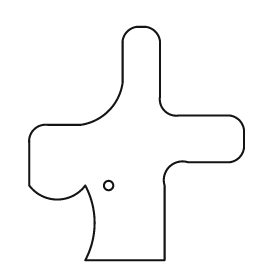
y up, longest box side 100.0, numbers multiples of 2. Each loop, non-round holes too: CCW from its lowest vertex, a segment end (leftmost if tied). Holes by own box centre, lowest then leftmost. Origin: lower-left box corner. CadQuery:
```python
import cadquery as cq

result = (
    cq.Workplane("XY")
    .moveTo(24.0, 0.0)
    .lineTo(58.0, 0.0)
    .lineTo(58.0, 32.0)
    .threePointArc((60.0, 40.0), (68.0, 42.0))
    .lineTo(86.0, 42.0)
    .threePointArc((90.0, 44.0), (92.0, 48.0))
    .lineTo(92.0, 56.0)
    .threePointArc((90.0, 60.0), (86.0, 62.0))
    .lineTo(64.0, 62.0)
    .threePointArc((58.0, 64.0), (56.0, 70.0))
    .lineTo(56.0, 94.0)
    .threePointArc((54.0, 98.0), (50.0, 100.0))
    .lineTo(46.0, 100.0)
    .threePointArc((42.0, 98.0), (40.0, 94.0))
    .lineTo(40.0, 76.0)
    .threePointArc((34.0, 64.0), (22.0, 58.0))
    .lineTo(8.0, 58.0)
    .threePointArc((2.0, 56.0), (0.0, 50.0))
    .lineTo(0.0, 32.0)
    .threePointArc((12.0, 26.0), (24.0, 32.0))
    .threePointArc((28.0, 16.0), (24.0, 0.0))
    .close()
    .moveTo(34.0, 32.0)
    .circle(2.0)
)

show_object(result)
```